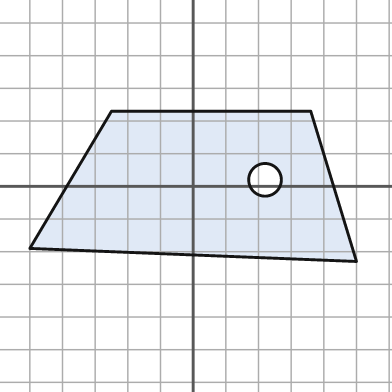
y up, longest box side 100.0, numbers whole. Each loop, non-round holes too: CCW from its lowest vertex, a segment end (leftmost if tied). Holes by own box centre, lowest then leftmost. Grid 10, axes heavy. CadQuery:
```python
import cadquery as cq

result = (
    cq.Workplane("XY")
    .moveTo(50.0, -23.0)
    .lineTo(36.0, 23.0)
    .lineTo(-25.0, 23.0)
    .lineTo(-50.0, -19.0)
    .close()
    .moveTo(22.0, 2.0)
    .circle(5.0)
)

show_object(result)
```